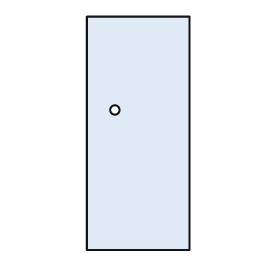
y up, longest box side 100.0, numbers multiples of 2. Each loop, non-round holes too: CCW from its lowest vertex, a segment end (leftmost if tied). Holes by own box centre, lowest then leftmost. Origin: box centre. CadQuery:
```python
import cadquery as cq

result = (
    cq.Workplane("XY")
    .moveTo(-22.0, -50.0)
    .lineTo(22.0, -50.0)
    .lineTo(22.0, 50.0)
    .lineTo(-22.0, 50.0)
    .close()
    .moveTo(-10.0, 10.0)
    .circle(2.0)
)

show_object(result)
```